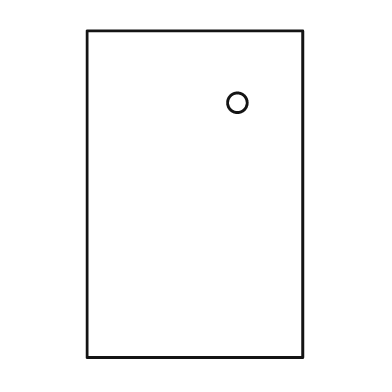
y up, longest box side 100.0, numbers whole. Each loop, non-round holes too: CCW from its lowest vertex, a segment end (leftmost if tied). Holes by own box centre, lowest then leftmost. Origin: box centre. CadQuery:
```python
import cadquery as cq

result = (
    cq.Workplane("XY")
    .moveTo(-33.0, -50.0)
    .lineTo(33.0, -50.0)
    .lineTo(33.0, 50.0)
    .lineTo(-33.0, 50.0)
    .close()
    .moveTo(13.0, 28.0)
    .circle(3.0)
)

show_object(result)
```